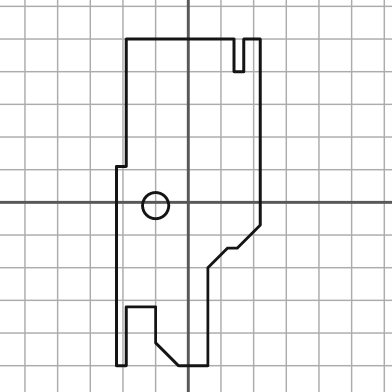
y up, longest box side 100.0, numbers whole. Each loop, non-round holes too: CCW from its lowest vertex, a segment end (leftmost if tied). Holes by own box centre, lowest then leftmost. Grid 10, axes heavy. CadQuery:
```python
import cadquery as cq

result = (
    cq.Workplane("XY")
    .moveTo(-22.0, -50.0)
    .lineTo(-19.0, -50.0)
    .lineTo(-19.0, -32.0)
    .lineTo(-10.0, -32.0)
    .lineTo(-10.0, -43.0)
    .lineTo(-3.0, -50.0)
    .lineTo(6.0, -50.0)
    .lineTo(6.0, -20.0)
    .lineTo(12.0, -14.0)
    .lineTo(15.0, -14.0)
    .lineTo(22.0, -7.0)
    .lineTo(22.0, 50.0)
    .lineTo(17.0, 50.0)
    .lineTo(17.0, 40.0)
    .lineTo(14.0, 40.0)
    .lineTo(14.0, 50.0)
    .lineTo(-19.0, 50.0)
    .lineTo(-19.0, 11.0)
    .lineTo(-22.0, 11.0)
    .close()
    .moveTo(-10.0, -1.0)
    .circle(4.0)
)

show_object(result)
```